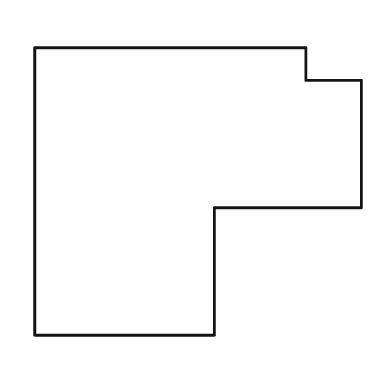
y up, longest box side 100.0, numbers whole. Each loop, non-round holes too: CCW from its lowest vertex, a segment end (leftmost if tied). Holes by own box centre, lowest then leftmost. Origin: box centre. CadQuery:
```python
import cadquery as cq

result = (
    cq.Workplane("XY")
    .moveTo(-50.0, -44.0)
    .lineTo(5.0, -44.0)
    .lineTo(5.0, -5.0)
    .lineTo(50.0, -5.0)
    .lineTo(50.0, 34.0)
    .lineTo(33.0, 34.0)
    .lineTo(33.0, 44.0)
    .lineTo(-50.0, 44.0)
    .close()
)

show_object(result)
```